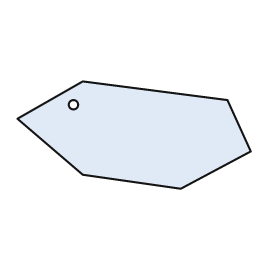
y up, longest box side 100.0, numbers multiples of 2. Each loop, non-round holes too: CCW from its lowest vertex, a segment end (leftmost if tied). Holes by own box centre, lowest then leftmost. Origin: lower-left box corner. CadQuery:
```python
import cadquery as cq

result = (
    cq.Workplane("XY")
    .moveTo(70.0, 0.0)
    .lineTo(100.0, 16.0)
    .lineTo(90.0, 38.0)
    .lineTo(28.0, 46.0)
    .lineTo(0.0, 30.0)
    .lineTo(28.0, 6.0)
    .close()
    .moveTo(24.0, 36.0)
    .circle(2.0)
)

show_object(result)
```